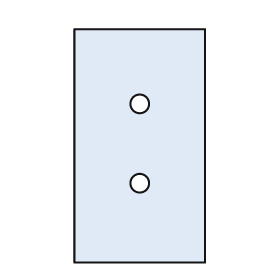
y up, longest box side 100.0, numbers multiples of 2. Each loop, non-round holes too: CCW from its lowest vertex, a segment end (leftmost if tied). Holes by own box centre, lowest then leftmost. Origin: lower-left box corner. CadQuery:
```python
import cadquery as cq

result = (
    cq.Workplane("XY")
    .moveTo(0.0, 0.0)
    .lineTo(56.0, 0.0)
    .lineTo(56.0, 100.0)
    .lineTo(0.0, 100.0)
    .close()
    .moveTo(28.0, 34.0)
    .circle(4.0)
    .moveTo(28.0, 68.0)
    .circle(4.0)
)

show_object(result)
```